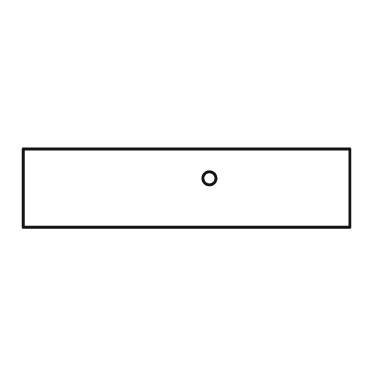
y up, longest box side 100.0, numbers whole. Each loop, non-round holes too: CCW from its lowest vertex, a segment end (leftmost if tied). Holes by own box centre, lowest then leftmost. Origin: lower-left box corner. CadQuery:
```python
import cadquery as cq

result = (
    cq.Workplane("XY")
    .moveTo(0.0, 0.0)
    .lineTo(100.0, 0.0)
    .lineTo(100.0, 24.0)
    .lineTo(0.0, 24.0)
    .close()
    .moveTo(57.0, 15.0)
    .circle(2.0)
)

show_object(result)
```